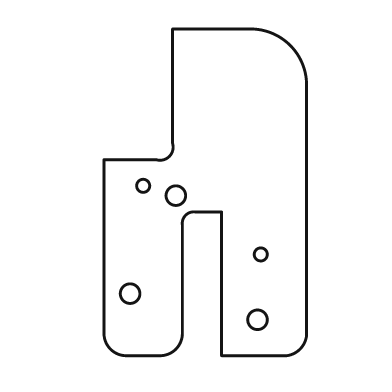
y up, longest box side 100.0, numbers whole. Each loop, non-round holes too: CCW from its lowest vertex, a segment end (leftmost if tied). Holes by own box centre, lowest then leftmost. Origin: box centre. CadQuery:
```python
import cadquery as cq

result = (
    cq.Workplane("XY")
    .moveTo(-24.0, -50.0)
    .lineTo(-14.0, -50.0)
    .threePointArc((-9.0, -48.0), (-7.0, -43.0))
    .lineTo(-7.0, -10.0)
    .threePointArc((-6.0, -7.0), (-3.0, -6.0))
    .lineTo(5.0, -6.0)
    .lineTo(5.0, -50.0)
    .lineTo(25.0, -50.0)
    .threePointArc((29.0, -48.0), (31.0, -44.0))
    .lineTo(31.0, 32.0)
    .threePointArc((26.0, 45.0), (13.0, 50.0))
    .lineTo(-10.0, 50.0)
    .lineTo(-10.0, 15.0)
    .threePointArc((-11.0, 11.0), (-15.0, 10.0))
    .lineTo(-31.0, 10.0)
    .lineTo(-31.0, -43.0)
    .threePointArc((-29.0, -48.0), (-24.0, -50.0))
    .close()
    .moveTo(16.0, -39.0)
    .circle(3.0)
    .moveTo(-23.0, -31.0)
    .circle(3.0)
    .moveTo(17.0, -19.0)
    .circle(2.0)
    .moveTo(-9.0, -1.0)
    .circle(3.0)
    .moveTo(-19.0, 2.0)
    .circle(2.0)
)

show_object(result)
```